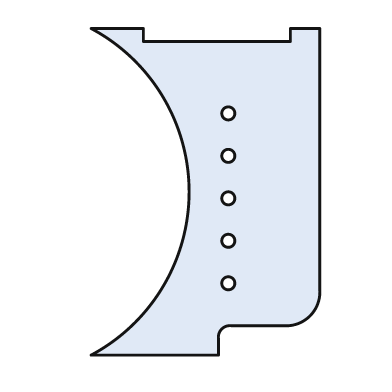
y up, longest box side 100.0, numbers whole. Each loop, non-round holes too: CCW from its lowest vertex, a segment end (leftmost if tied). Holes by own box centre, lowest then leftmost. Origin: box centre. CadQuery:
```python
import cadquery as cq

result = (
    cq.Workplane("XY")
    .moveTo(-35.0, -50.0)
    .lineTo(4.0, -50.0)
    .lineTo(4.0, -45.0)
    .threePointArc((5.0, -42.0), (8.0, -41.0))
    .lineTo(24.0, -41.0)
    .threePointArc((32.0, -38.0), (35.0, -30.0))
    .lineTo(35.0, 50.0)
    .lineTo(26.0, 50.0)
    .lineTo(26.0, 46.0)
    .lineTo(-19.0, 46.0)
    .lineTo(-19.0, 50.0)
    .lineTo(-35.0, 50.0)
    .threePointArc((-5.0, 0.0), (-35.0, -50.0))
    .close()
    .moveTo(7.0, -28.0)
    .circle(2.0)
    .moveTo(7.0, -15.0)
    .circle(2.0)
    .moveTo(7.0, -2.0)
    .circle(2.0)
    .moveTo(7.0, 11.0)
    .circle(2.0)
    .moveTo(7.0, 24.0)
    .circle(2.0)
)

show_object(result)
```